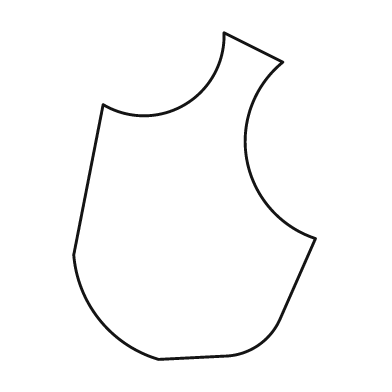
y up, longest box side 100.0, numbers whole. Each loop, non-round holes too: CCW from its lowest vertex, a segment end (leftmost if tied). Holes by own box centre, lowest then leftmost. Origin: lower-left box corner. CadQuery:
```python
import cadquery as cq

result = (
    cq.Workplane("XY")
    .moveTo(26.0, 0.0)
    .lineTo(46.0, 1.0)
    .threePointArc((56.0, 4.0), (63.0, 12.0))
    .lineTo(74.0, 37.0)
    .threePointArc((53.0, 61.0), (64.0, 91.0))
    .lineTo(46.0, 100.0)
    .threePointArc((34.0, 78.0), (9.0, 78.0))
    .lineTo(0.0, 32.0)
    .threePointArc((8.0, 12.0), (26.0, 0.0))
    .close()
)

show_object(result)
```